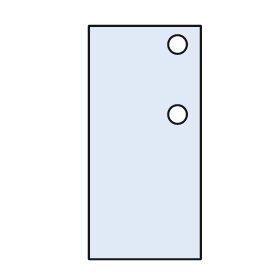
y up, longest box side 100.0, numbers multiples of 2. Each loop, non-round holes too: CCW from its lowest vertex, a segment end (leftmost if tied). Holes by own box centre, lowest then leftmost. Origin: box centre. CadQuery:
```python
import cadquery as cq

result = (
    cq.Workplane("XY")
    .moveTo(-24.0, -50.0)
    .lineTo(24.0, -50.0)
    .lineTo(24.0, 50.0)
    .lineTo(-24.0, 50.0)
    .close()
    .moveTo(14.0, 12.0)
    .circle(4.0)
    .moveTo(14.0, 42.0)
    .circle(4.0)
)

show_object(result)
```